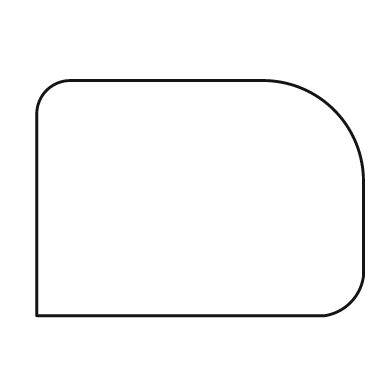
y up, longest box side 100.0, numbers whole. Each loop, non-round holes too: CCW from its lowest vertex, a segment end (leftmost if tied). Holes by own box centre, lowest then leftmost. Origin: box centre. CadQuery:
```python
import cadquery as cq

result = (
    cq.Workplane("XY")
    .moveTo(-50.0, -36.0)
    .lineTo(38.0, -36.0)
    .threePointArc((46.0, -32.0), (50.0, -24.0))
    .lineTo(50.0, 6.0)
    .threePointArc((41.0, 27.0), (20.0, 36.0))
    .lineTo(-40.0, 36.0)
    .threePointArc((-47.0, 33.0), (-50.0, 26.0))
    .close()
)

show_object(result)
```